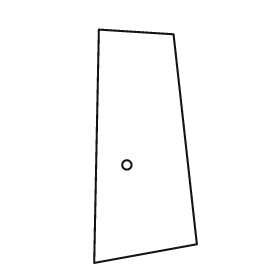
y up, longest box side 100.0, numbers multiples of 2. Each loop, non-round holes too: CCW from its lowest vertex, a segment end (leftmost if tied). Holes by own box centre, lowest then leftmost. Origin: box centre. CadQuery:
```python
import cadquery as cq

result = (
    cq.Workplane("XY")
    .moveTo(-22.0, -50.0)
    .lineTo(22.0, -42.0)
    .lineTo(12.0, 48.0)
    .lineTo(-20.0, 50.0)
    .close()
    .moveTo(-8.0, -8.0)
    .circle(2.0)
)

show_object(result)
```